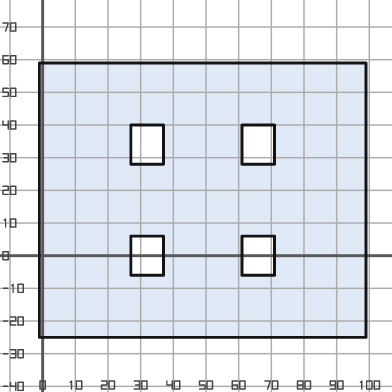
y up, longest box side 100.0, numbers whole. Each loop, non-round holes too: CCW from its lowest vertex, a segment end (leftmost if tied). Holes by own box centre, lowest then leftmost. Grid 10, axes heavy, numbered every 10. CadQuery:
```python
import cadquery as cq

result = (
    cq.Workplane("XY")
    .moveTo(-1.0, -25.0)
    .lineTo(99.0, -25.0)
    .lineTo(99.0, 59.0)
    .lineTo(-1.0, 59.0)
    .close()
    .moveTo(27.0, -6.0)
    .lineTo(37.0, -6.0)
    .lineTo(37.0, 6.0)
    .lineTo(27.0, 6.0)
    .close()
    .moveTo(61.0, -6.0)
    .lineTo(71.0, -6.0)
    .lineTo(71.0, 6.0)
    .lineTo(61.0, 6.0)
    .close()
    .moveTo(27.0, 28.0)
    .lineTo(37.0, 28.0)
    .lineTo(37.0, 40.0)
    .lineTo(27.0, 40.0)
    .close()
    .moveTo(61.0, 28.0)
    .lineTo(71.0, 28.0)
    .lineTo(71.0, 40.0)
    .lineTo(61.0, 40.0)
    .close()
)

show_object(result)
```